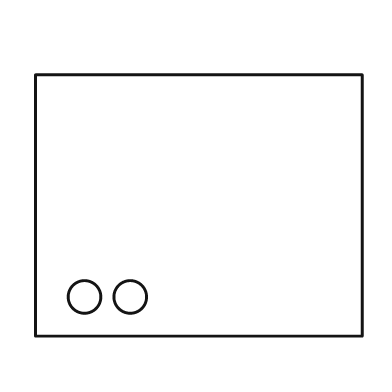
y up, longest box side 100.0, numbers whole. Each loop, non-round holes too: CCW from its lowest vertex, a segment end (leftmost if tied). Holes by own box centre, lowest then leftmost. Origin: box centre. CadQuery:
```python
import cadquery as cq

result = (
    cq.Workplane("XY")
    .moveTo(-50.0, -40.0)
    .lineTo(50.0, -40.0)
    .lineTo(50.0, 40.0)
    .lineTo(-50.0, 40.0)
    .close()
    .moveTo(-35.0, -28.0)
    .circle(5.0)
    .moveTo(-21.0, -28.0)
    .circle(5.0)
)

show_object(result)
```